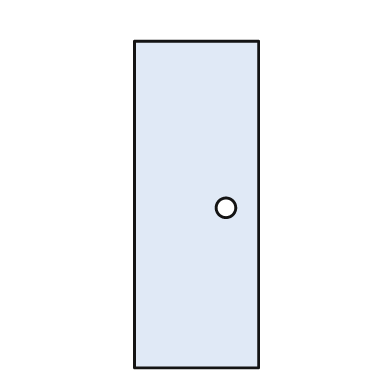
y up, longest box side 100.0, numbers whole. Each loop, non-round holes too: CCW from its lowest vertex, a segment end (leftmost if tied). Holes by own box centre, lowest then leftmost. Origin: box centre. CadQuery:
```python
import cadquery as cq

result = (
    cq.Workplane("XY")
    .moveTo(-19.0, -50.0)
    .lineTo(19.0, -50.0)
    .lineTo(19.0, 50.0)
    .lineTo(-19.0, 50.0)
    .close()
    .moveTo(9.0, -1.0)
    .circle(3.0)
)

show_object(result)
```